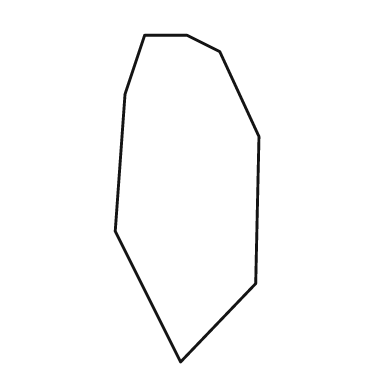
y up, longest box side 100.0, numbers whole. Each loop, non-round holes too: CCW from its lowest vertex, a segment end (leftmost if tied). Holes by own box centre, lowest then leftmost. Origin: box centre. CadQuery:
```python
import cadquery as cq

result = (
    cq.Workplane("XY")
    .moveTo(-2.0, -50.0)
    .lineTo(21.0, -26.0)
    .lineTo(22.0, 19.0)
    .lineTo(10.0, 45.0)
    .lineTo(0.0, 50.0)
    .lineTo(-13.0, 50.0)
    .lineTo(-19.0, 32.0)
    .lineTo(-22.0, -10.0)
    .close()
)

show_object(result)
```